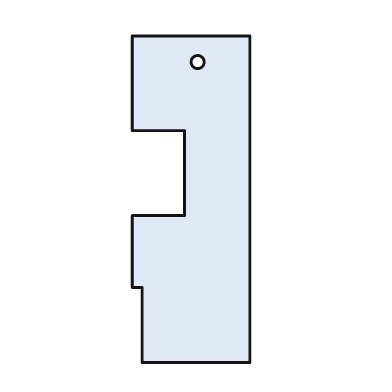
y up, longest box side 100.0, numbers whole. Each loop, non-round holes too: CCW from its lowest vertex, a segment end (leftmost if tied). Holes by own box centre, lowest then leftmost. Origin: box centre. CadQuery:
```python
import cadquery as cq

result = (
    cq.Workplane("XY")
    .moveTo(-15.0, -50.0)
    .lineTo(18.0, -50.0)
    .lineTo(18.0, 50.0)
    .lineTo(-18.0, 50.0)
    .lineTo(-18.0, 21.0)
    .lineTo(-2.0, 21.0)
    .lineTo(-2.0, -5.0)
    .lineTo(-18.0, -5.0)
    .lineTo(-18.0, -27.0)
    .lineTo(-15.0, -27.0)
    .close()
    .moveTo(2.0, 42.0)
    .circle(2.0)
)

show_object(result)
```